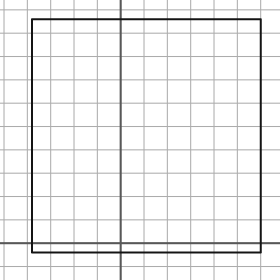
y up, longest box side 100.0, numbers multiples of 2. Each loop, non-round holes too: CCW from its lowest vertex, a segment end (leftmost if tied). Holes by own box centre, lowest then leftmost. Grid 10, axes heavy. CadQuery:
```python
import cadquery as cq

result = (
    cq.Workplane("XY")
    .moveTo(-38.0, -4.0)
    .lineTo(60.0, -4.0)
    .lineTo(60.0, 96.0)
    .lineTo(-38.0, 96.0)
    .close()
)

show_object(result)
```